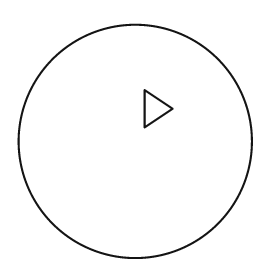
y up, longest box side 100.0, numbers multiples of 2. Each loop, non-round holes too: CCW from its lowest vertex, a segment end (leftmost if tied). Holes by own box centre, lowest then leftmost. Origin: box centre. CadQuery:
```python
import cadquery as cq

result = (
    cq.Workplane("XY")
    .moveTo(0.0, 0.0)
    .circle(50.0)
    .moveTo(4.0, 6.0)
    .lineTo(16.0, 14.0)
    .lineTo(4.0, 22.0)
    .close()
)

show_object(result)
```